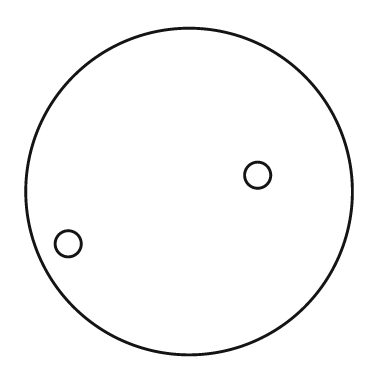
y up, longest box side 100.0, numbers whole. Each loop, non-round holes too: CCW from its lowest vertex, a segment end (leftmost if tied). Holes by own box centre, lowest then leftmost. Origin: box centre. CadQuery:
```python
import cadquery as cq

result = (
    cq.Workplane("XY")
    .moveTo(0.0, 0.0)
    .circle(50.0)
    .moveTo(-37.0, -16.0)
    .circle(4.0)
    .moveTo(21.0, 5.0)
    .circle(4.0)
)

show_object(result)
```